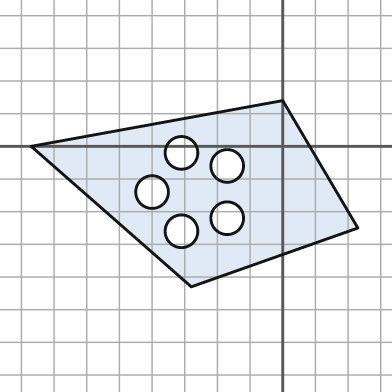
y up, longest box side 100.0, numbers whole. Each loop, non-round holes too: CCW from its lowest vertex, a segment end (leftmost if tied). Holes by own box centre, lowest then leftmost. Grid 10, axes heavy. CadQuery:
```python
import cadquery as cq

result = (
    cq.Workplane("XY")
    .moveTo(-28.0, -43.0)
    .lineTo(23.0, -25.0)
    .lineTo(0.0, 14.0)
    .lineTo(-77.0, 0.0)
    .close()
    .moveTo(-31.0, -26.0)
    .circle(5.0)
    .moveTo(-17.0, -22.0)
    .circle(5.0)
    .moveTo(-40.0, -14.0)
    .circle(5.0)
    .moveTo(-17.0, -6.0)
    .circle(5.0)
    .moveTo(-31.0, -2.0)
    .circle(5.0)
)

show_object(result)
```